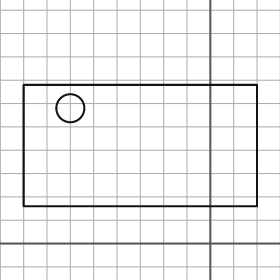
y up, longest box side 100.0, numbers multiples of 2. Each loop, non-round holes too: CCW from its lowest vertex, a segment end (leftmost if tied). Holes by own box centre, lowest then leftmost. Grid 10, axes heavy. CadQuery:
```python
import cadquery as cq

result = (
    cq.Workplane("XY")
    .moveTo(-80.0, 16.0)
    .lineTo(20.0, 16.0)
    .lineTo(20.0, 68.0)
    .lineTo(-80.0, 68.0)
    .close()
    .moveTo(-60.0, 58.0)
    .circle(6.0)
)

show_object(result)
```